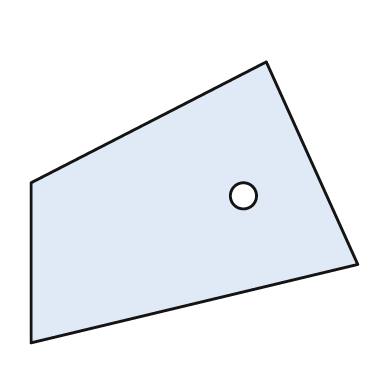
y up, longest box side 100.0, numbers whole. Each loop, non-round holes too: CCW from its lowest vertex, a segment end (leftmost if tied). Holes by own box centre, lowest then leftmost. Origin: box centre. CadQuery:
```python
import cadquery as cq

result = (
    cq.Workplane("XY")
    .moveTo(-50.0, -43.0)
    .lineTo(50.0, -19.0)
    .lineTo(22.0, 43.0)
    .lineTo(-50.0, 6.0)
    .close()
    .moveTo(15.0, 2.0)
    .circle(4.0)
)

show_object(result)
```